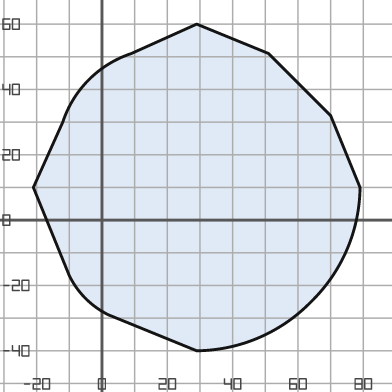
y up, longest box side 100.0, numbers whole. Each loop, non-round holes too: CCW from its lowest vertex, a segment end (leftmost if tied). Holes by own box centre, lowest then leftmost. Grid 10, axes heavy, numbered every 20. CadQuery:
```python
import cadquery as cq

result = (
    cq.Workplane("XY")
    .moveTo(29.0, -40.0)
    .threePointArc((48.0, -36.0), (64.0, -25.0))
    .threePointArc((75.0, -9.0), (79.0, 10.0))
    .lineTo(70.0, 32.0)
    .lineTo(51.0, 51.0)
    .lineTo(29.0, 60.0)
    .lineTo(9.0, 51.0)
    .threePointArc((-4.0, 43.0), (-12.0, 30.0))
    .lineTo(-21.0, 10.0)
    .lineTo(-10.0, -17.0)
    .threePointArc((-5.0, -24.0), (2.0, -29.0))
    .close()
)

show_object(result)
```